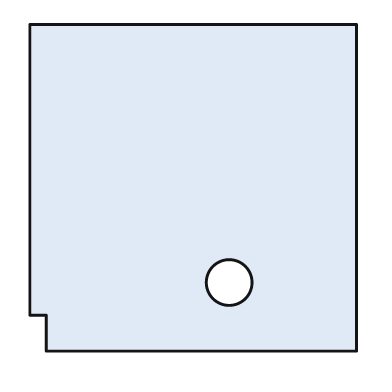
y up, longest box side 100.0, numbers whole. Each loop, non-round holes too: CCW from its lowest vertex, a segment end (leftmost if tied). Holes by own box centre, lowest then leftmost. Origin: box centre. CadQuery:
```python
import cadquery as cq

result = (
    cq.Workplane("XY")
    .moveTo(-45.0, -50.0)
    .lineTo(50.0, -50.0)
    .lineTo(50.0, 50.0)
    .lineTo(-50.0, 50.0)
    .lineTo(-50.0, -39.0)
    .lineTo(-45.0, -39.0)
    .close()
    .moveTo(11.0, -29.0)
    .circle(7.0)
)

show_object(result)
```